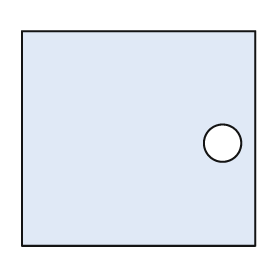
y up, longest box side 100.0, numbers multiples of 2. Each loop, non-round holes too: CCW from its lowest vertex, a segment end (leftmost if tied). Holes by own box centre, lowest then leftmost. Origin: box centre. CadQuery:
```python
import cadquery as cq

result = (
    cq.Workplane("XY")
    .moveTo(-50.0, -46.0)
    .lineTo(50.0, -46.0)
    .lineTo(50.0, 46.0)
    .lineTo(-50.0, 46.0)
    .close()
    .moveTo(36.0, -2.0)
    .circle(8.0)
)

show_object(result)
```